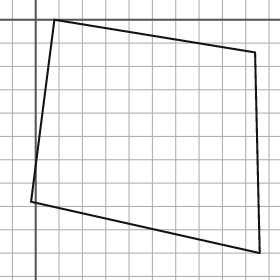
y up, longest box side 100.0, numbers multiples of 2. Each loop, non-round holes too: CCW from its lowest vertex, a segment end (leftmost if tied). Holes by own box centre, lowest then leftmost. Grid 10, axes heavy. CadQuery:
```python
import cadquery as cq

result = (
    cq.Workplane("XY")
    .moveTo(96.0, -100.0)
    .lineTo(94.0, -14.0)
    .lineTo(8.0, 0.0)
    .lineTo(-2.0, -78.0)
    .close()
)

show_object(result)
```